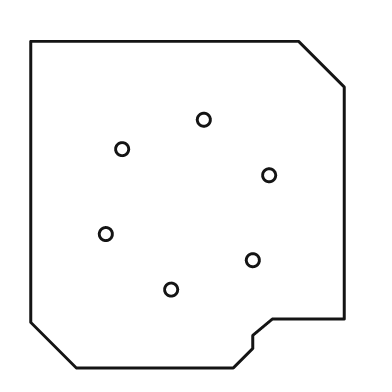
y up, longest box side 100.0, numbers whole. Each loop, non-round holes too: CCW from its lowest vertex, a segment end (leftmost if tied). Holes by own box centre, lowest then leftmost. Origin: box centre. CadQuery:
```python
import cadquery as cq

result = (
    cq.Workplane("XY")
    .moveTo(-34.0, -50.0)
    .lineTo(14.0, -50.0)
    .lineTo(20.0, -44.0)
    .lineTo(20.0, -40.0)
    .lineTo(26.0, -35.0)
    .lineTo(48.0, -35.0)
    .lineTo(48.0, 36.0)
    .lineTo(34.0, 50.0)
    .lineTo(-48.0, 50.0)
    .lineTo(-48.0, -36.0)
    .close()
    .moveTo(-5.0, -26.0)
    .circle(2.0)
    .moveTo(20.0, -17.0)
    .circle(2.0)
    .moveTo(-25.0, -9.0)
    .circle(2.0)
    .moveTo(25.0, 9.0)
    .circle(2.0)
    .moveTo(-20.0, 17.0)
    .circle(2.0)
    .moveTo(5.0, 26.0)
    .circle(2.0)
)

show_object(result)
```